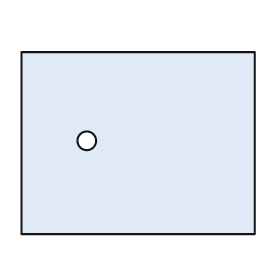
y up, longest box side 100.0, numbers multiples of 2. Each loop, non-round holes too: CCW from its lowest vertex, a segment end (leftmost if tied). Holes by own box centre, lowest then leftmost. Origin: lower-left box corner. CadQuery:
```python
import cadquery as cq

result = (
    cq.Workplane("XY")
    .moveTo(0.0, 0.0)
    .lineTo(100.0, 0.0)
    .lineTo(100.0, 78.0)
    .lineTo(0.0, 78.0)
    .close()
    .moveTo(28.0, 40.0)
    .circle(4.0)
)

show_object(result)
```